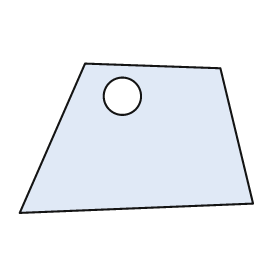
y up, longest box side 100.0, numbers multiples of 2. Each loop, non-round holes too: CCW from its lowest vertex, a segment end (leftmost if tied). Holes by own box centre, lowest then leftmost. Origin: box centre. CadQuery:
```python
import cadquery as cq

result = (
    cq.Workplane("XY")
    .moveTo(-50.0, -32.0)
    .lineTo(50.0, -28.0)
    .lineTo(36.0, 30.0)
    .lineTo(-22.0, 32.0)
    .close()
    .moveTo(-6.0, 18.0)
    .circle(8.0)
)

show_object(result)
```